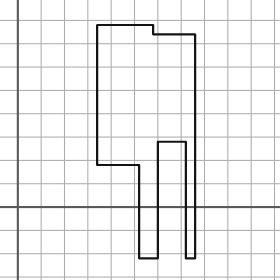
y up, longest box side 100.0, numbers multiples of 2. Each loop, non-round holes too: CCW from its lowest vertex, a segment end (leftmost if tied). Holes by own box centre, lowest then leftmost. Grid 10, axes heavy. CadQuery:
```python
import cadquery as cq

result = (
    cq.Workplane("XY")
    .moveTo(52.0, -22.0)
    .lineTo(60.0, -22.0)
    .lineTo(60.0, 28.0)
    .lineTo(72.0, 28.0)
    .lineTo(72.0, -22.0)
    .lineTo(76.0, -22.0)
    .lineTo(76.0, 74.0)
    .lineTo(58.0, 74.0)
    .lineTo(58.0, 78.0)
    .lineTo(34.0, 78.0)
    .lineTo(34.0, 18.0)
    .lineTo(52.0, 18.0)
    .close()
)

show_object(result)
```